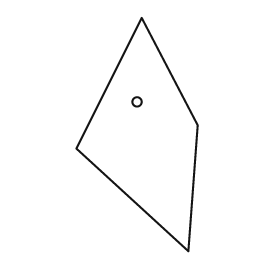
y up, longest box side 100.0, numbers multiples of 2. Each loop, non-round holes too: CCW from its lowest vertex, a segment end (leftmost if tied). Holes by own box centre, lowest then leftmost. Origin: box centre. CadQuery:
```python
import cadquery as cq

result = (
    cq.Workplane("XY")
    .moveTo(22.0, -50.0)
    .lineTo(26.0, 4.0)
    .lineTo(2.0, 50.0)
    .lineTo(-26.0, -6.0)
    .close()
    .moveTo(0.0, 14.0)
    .circle(2.0)
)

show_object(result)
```